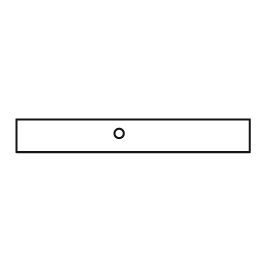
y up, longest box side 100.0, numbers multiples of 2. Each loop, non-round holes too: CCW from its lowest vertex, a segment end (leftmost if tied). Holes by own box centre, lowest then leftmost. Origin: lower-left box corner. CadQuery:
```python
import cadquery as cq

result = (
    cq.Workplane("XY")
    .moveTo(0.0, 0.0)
    .lineTo(100.0, 0.0)
    .lineTo(100.0, 14.0)
    .lineTo(0.0, 14.0)
    .close()
    .moveTo(44.0, 8.0)
    .circle(2.0)
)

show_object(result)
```